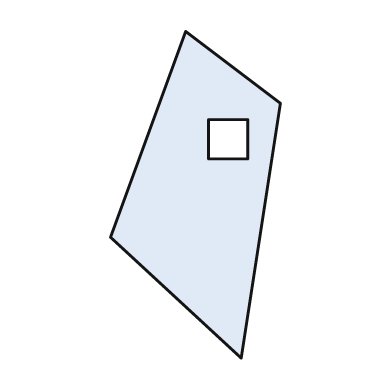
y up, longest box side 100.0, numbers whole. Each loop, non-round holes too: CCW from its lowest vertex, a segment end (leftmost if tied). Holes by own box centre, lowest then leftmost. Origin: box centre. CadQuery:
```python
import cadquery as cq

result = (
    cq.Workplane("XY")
    .moveTo(14.0, -50.0)
    .lineTo(26.0, 28.0)
    .lineTo(-3.0, 50.0)
    .lineTo(-26.0, -13.0)
    .close()
    .moveTo(4.0, 11.0)
    .lineTo(16.0, 11.0)
    .lineTo(16.0, 23.0)
    .lineTo(4.0, 23.0)
    .close()
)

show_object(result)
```